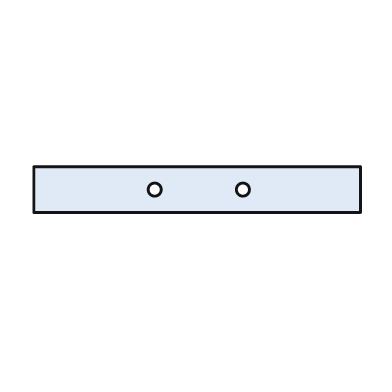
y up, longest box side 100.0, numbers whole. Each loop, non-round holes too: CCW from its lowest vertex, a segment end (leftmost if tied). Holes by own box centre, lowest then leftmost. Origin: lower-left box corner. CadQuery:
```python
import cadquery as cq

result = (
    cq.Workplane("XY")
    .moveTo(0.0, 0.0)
    .lineTo(100.0, 0.0)
    .lineTo(100.0, 14.0)
    .lineTo(0.0, 14.0)
    .close()
    .moveTo(37.0, 7.0)
    .circle(2.0)
    .moveTo(64.0, 7.0)
    .circle(2.0)
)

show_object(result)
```